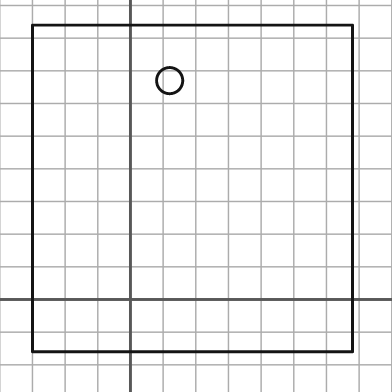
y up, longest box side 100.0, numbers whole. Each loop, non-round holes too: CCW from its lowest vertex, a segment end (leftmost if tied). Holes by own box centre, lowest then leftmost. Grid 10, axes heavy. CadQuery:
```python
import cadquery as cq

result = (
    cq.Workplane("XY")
    .moveTo(-30.0, -16.0)
    .lineTo(68.0, -16.0)
    .lineTo(68.0, 84.0)
    .lineTo(-30.0, 84.0)
    .close()
    .moveTo(12.0, 67.0)
    .circle(4.0)
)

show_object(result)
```